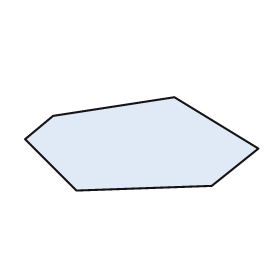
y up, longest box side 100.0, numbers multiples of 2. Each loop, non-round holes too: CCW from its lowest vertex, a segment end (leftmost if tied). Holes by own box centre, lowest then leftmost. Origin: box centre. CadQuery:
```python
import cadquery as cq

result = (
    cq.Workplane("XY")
    .moveTo(-28.0, -20.0)
    .lineTo(30.0, -18.0)
    .lineTo(50.0, -2.0)
    .lineTo(14.0, 20.0)
    .lineTo(-38.0, 12.0)
    .lineTo(-50.0, 2.0)
    .close()
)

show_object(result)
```